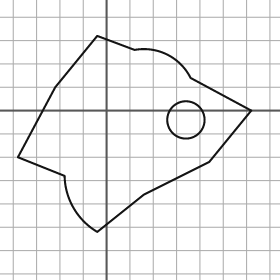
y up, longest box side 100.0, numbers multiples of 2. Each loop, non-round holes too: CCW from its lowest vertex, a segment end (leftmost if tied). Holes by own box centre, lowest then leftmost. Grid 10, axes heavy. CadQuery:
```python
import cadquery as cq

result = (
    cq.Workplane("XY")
    .moveTo(-4.0, -52.0)
    .lineTo(16.0, -36.0)
    .lineTo(44.0, -22.0)
    .lineTo(62.0, 0.0)
    .lineTo(36.0, 14.0)
    .threePointArc((26.0, 24.0), (12.0, 26.0))
    .lineTo(-4.0, 32.0)
    .lineTo(-22.0, 10.0)
    .lineTo(-38.0, -20.0)
    .lineTo(-18.0, -28.0)
    .threePointArc((-14.0, -42.0), (-4.0, -52.0))
    .close()
    .moveTo(34.0, -4.0)
    .circle(8.0)
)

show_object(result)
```